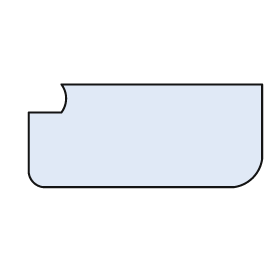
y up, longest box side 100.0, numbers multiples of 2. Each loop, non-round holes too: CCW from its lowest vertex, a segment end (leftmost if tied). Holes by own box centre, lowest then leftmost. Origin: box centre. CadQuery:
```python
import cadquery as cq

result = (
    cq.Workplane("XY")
    .moveTo(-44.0, -22.0)
    .lineTo(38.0, -22.0)
    .threePointArc((46.0, -18.0), (50.0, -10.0))
    .lineTo(50.0, 22.0)
    .lineTo(-36.0, 22.0)
    .threePointArc((-34.0, 16.0), (-36.0, 10.0))
    .lineTo(-50.0, 10.0)
    .lineTo(-50.0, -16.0)
    .threePointArc((-48.0, -20.0), (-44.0, -22.0))
    .close()
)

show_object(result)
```